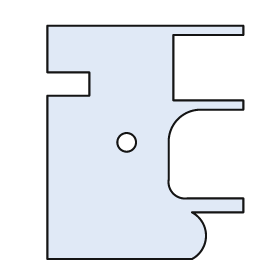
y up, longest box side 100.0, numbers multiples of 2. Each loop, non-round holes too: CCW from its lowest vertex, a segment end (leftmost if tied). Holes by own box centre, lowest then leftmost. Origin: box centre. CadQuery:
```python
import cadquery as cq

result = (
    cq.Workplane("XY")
    .moveTo(-42.0, -50.0)
    .lineTo(20.0, -50.0)
    .threePointArc((26.0, -40.0), (20.0, -30.0))
    .lineTo(42.0, -30.0)
    .lineTo(42.0, -24.0)
    .lineTo(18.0, -24.0)
    .threePointArc((12.0, -22.0), (10.0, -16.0))
    .lineTo(10.0, 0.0)
    .threePointArc((14.0, 10.0), (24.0, 14.0))
    .lineTo(42.0, 14.0)
    .lineTo(42.0, 18.0)
    .lineTo(12.0, 18.0)
    .lineTo(12.0, 46.0)
    .lineTo(42.0, 46.0)
    .lineTo(42.0, 50.0)
    .lineTo(-42.0, 50.0)
    .lineTo(-42.0, 30.0)
    .lineTo(-24.0, 30.0)
    .lineTo(-24.0, 20.0)
    .lineTo(-42.0, 20.0)
    .close()
    .moveTo(-8.0, 0.0)
    .circle(4.0)
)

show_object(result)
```